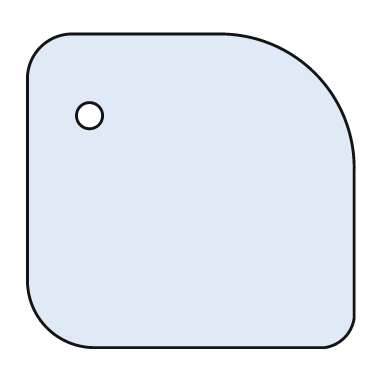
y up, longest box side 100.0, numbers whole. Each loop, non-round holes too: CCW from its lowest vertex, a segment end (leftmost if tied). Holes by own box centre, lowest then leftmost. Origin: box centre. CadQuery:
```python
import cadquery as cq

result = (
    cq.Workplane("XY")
    .moveTo(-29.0, -48.0)
    .lineTo(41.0, -48.0)
    .threePointArc((47.0, -45.0), (50.0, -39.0))
    .lineTo(50.0, 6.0)
    .threePointArc((38.0, 36.0), (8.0, 48.0))
    .lineTo(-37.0, 48.0)
    .threePointArc((-46.0, 44.0), (-50.0, 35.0))
    .lineTo(-50.0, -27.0)
    .threePointArc((-44.0, -42.0), (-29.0, -48.0))
    .close()
    .moveTo(-31.0, 23.0)
    .circle(4.0)
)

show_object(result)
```